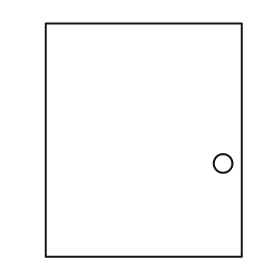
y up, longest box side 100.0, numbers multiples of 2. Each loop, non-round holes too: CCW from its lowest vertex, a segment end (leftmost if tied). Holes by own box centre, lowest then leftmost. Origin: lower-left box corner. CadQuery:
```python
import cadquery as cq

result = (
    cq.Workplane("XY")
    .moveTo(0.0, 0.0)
    .lineTo(84.0, 0.0)
    .lineTo(84.0, 100.0)
    .lineTo(0.0, 100.0)
    .close()
    .moveTo(76.0, 40.0)
    .circle(4.0)
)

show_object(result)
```